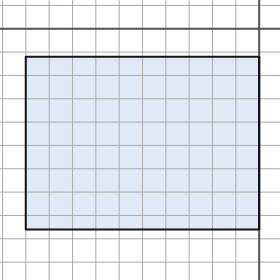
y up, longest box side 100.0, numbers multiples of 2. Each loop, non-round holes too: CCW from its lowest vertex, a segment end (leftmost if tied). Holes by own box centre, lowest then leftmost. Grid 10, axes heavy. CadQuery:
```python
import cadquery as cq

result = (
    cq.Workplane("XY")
    .moveTo(-100.0, -86.0)
    .lineTo(0.0, -86.0)
    .lineTo(0.0, -12.0)
    .lineTo(-100.0, -12.0)
    .close()
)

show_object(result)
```